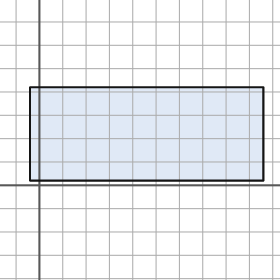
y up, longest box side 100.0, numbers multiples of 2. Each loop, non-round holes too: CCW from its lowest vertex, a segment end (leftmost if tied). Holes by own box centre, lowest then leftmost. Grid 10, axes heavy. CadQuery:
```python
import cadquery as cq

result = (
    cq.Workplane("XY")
    .moveTo(-4.0, 2.0)
    .lineTo(96.0, 2.0)
    .lineTo(96.0, 42.0)
    .lineTo(-4.0, 42.0)
    .close()
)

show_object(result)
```